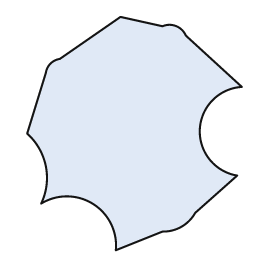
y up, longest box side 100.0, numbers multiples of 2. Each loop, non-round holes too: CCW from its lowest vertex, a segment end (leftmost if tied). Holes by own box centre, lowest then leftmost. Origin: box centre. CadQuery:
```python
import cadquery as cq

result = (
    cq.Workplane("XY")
    .moveTo(-8.0, -50.0)
    .lineTo(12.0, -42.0)
    .threePointArc((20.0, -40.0), (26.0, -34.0))
    .lineTo(44.0, -18.0)
    .threePointArc((28.0, 2.0), (46.0, 20.0))
    .lineTo(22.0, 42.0)
    .threePointArc((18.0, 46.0), (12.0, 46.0))
    .lineTo(-6.0, 50.0)
    .lineTo(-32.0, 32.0)
    .threePointArc((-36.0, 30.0), (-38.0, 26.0))
    .lineTo(-46.0, 0.0)
    .threePointArc((-38.0, -14.0), (-40.0, -30.0))
    .threePointArc((-18.0, -30.0), (-8.0, -50.0))
    .close()
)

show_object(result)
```